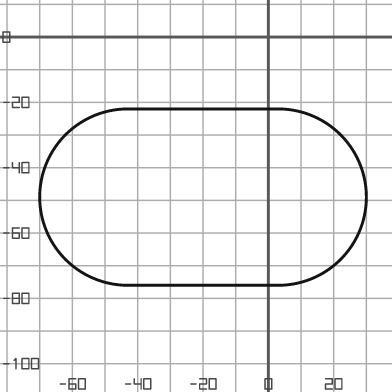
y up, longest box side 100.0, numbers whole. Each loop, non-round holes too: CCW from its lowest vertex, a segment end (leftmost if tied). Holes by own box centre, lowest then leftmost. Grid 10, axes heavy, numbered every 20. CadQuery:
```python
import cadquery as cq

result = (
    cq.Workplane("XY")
    .moveTo(-43.0, -76.0)
    .lineTo(3.0, -76.0)
    .threePointArc((30.0, -49.0), (3.0, -22.0))
    .lineTo(-43.0, -22.0)
    .threePointArc((-70.0, -49.0), (-43.0, -76.0))
    .close()
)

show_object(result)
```